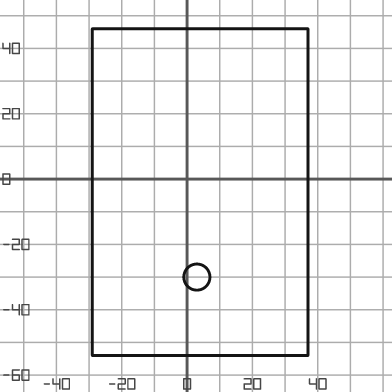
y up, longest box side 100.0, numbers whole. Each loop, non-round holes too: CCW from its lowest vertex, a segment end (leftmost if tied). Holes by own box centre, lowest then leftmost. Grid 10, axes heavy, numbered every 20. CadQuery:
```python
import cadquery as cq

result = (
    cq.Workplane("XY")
    .moveTo(-29.0, -54.0)
    .lineTo(37.0, -54.0)
    .lineTo(37.0, 46.0)
    .lineTo(-29.0, 46.0)
    .close()
    .moveTo(3.0, -30.0)
    .circle(4.0)
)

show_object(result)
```